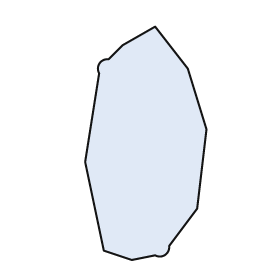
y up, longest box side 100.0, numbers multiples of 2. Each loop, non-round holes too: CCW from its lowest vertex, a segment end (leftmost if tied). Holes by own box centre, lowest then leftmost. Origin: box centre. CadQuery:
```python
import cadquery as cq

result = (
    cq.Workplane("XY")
    .moveTo(-6.0, -50.0)
    .lineTo(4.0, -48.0)
    .threePointArc((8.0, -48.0), (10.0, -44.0))
    .lineTo(22.0, -28.0)
    .lineTo(26.0, 6.0)
    .lineTo(18.0, 32.0)
    .lineTo(4.0, 50.0)
    .lineTo(-10.0, 42.0)
    .lineTo(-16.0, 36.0)
    .threePointArc((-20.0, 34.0), (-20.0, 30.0))
    .lineTo(-26.0, -8.0)
    .lineTo(-18.0, -46.0)
    .close()
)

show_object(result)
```